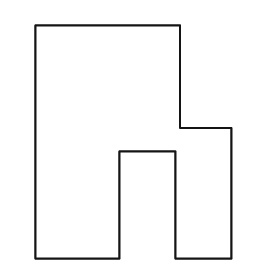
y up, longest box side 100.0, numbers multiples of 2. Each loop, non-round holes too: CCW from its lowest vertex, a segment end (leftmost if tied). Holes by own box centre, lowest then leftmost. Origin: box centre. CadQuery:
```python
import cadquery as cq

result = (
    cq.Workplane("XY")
    .moveTo(-42.0, -50.0)
    .lineTo(-6.0, -50.0)
    .lineTo(-6.0, -4.0)
    .lineTo(18.0, -4.0)
    .lineTo(18.0, -50.0)
    .lineTo(42.0, -50.0)
    .lineTo(42.0, 6.0)
    .lineTo(20.0, 6.0)
    .lineTo(20.0, 50.0)
    .lineTo(-42.0, 50.0)
    .close()
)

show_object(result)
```